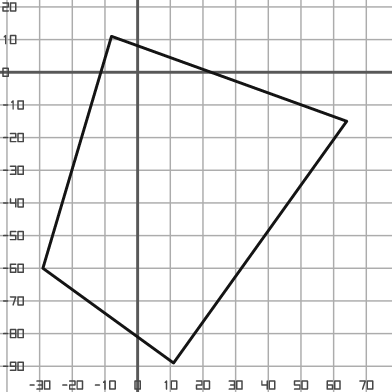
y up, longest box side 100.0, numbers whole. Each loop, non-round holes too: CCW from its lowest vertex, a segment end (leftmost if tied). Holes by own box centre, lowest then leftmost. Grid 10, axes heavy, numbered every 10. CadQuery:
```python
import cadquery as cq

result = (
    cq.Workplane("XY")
    .moveTo(11.0, -89.0)
    .lineTo(64.0, -15.0)
    .lineTo(-8.0, 11.0)
    .lineTo(-29.0, -60.0)
    .close()
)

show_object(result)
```